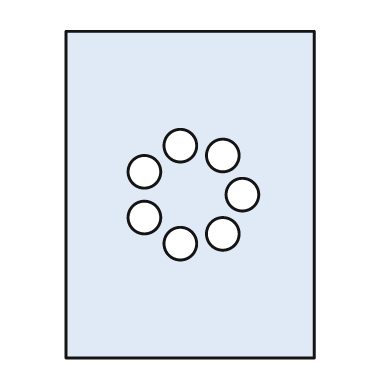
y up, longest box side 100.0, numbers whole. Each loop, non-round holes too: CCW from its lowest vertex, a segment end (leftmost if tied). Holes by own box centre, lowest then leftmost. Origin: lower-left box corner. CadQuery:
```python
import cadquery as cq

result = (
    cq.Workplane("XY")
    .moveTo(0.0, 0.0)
    .lineTo(76.0, 0.0)
    .lineTo(76.0, 100.0)
    .lineTo(0.0, 100.0)
    .close()
    .moveTo(35.0, 35.0)
    .circle(5.0)
    .moveTo(48.0, 38.0)
    .circle(5.0)
    .moveTo(24.0, 43.0)
    .circle(5.0)
    .moveTo(54.0, 50.0)
    .circle(5.0)
    .moveTo(24.0, 57.0)
    .circle(5.0)
    .moveTo(48.0, 62.0)
    .circle(5.0)
    .moveTo(35.0, 65.0)
    .circle(5.0)
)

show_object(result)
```